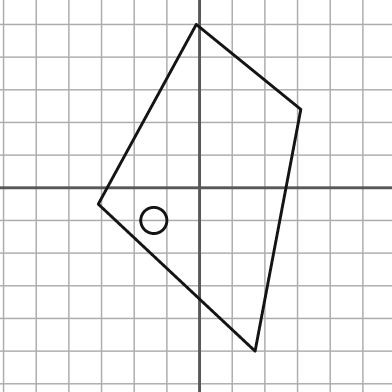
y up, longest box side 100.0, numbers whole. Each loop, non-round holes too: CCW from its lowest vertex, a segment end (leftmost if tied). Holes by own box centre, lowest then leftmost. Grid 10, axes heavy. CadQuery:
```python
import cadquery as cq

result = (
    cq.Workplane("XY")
    .moveTo(17.0, -50.0)
    .lineTo(31.0, 24.0)
    .lineTo(-1.0, 50.0)
    .lineTo(-31.0, -5.0)
    .close()
    .moveTo(-14.0, -10.0)
    .circle(4.0)
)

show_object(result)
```